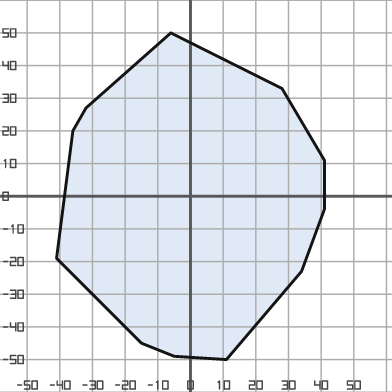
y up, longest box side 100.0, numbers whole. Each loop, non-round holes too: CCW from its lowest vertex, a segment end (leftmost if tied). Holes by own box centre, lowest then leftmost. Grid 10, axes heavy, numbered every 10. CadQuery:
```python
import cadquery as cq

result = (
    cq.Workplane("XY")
    .moveTo(11.0, -50.0)
    .lineTo(34.0, -23.0)
    .lineTo(41.0, -4.0)
    .lineTo(41.0, 11.0)
    .lineTo(28.0, 33.0)
    .lineTo(-6.0, 50.0)
    .lineTo(-32.0, 27.0)
    .lineTo(-36.0, 20.0)
    .lineTo(-41.0, -19.0)
    .lineTo(-15.0, -45.0)
    .lineTo(-5.0, -49.0)
    .close()
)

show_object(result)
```